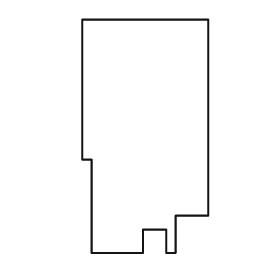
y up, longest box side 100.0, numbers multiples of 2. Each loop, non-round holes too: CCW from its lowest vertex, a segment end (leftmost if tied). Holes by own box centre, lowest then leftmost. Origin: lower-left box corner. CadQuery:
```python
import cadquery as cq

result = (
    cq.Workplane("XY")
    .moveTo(4.0, 0.0)
    .lineTo(26.0, 0.0)
    .lineTo(26.0, 10.0)
    .lineTo(36.0, 10.0)
    .lineTo(36.0, 0.0)
    .lineTo(40.0, 0.0)
    .lineTo(40.0, 16.0)
    .lineTo(54.0, 16.0)
    .lineTo(54.0, 100.0)
    .lineTo(0.0, 100.0)
    .lineTo(0.0, 40.0)
    .lineTo(4.0, 40.0)
    .close()
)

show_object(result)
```